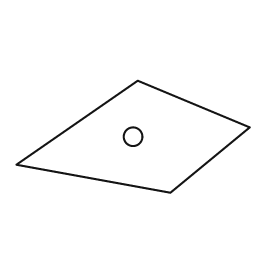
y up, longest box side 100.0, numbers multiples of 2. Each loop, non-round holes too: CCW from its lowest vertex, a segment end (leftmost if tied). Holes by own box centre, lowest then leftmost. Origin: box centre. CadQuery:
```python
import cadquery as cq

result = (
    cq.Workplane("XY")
    .moveTo(16.0, -24.0)
    .lineTo(50.0, 4.0)
    .lineTo(2.0, 24.0)
    .lineTo(-50.0, -12.0)
    .close()
    .moveTo(0.0, 0.0)
    .circle(4.0)
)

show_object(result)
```